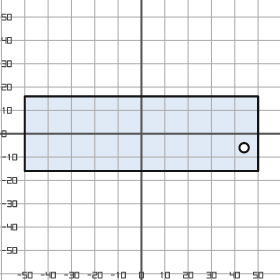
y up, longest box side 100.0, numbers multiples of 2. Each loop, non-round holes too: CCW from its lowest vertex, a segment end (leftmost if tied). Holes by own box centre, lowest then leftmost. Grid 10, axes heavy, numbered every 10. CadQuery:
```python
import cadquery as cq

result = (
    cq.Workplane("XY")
    .moveTo(-50.0, -16.0)
    .lineTo(50.0, -16.0)
    .lineTo(50.0, 16.0)
    .lineTo(-50.0, 16.0)
    .close()
    .moveTo(44.0, -6.0)
    .circle(2.0)
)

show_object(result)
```